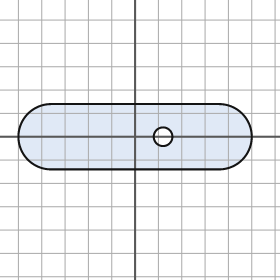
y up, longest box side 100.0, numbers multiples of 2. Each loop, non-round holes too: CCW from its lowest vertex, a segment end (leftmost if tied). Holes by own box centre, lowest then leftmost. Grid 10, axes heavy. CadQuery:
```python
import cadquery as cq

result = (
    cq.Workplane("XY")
    .moveTo(-36.0, -14.0)
    .lineTo(36.0, -14.0)
    .threePointArc((50.0, 0.0), (36.0, 14.0))
    .lineTo(-36.0, 14.0)
    .threePointArc((-50.0, 0.0), (-36.0, -14.0))
    .close()
    .moveTo(12.0, 0.0)
    .circle(4.0)
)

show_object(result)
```